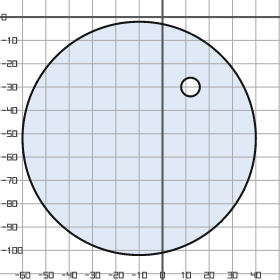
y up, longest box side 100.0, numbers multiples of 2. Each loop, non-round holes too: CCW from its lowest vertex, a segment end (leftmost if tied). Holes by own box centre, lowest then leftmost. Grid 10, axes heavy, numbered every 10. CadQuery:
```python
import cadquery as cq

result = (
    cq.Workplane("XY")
    .moveTo(-10.0, -52.0)
    .circle(50.0)
    .moveTo(12.0, -30.0)
    .circle(4.0)
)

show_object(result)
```